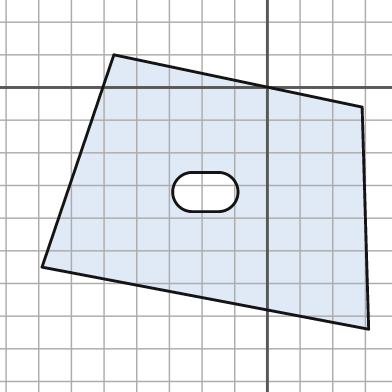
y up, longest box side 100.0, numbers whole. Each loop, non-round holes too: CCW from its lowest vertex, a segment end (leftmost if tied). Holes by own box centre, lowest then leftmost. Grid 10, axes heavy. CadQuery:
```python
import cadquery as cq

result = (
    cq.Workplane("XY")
    .moveTo(31.0, -74.0)
    .lineTo(29.0, -6.0)
    .lineTo(-47.0, 10.0)
    .lineTo(-69.0, -55.0)
    .close()
    .moveTo(-23.0, -38.0)
    .lineTo(-15.0, -38.0)
    .threePointArc((-9.0, -32.0), (-15.0, -26.0))
    .lineTo(-23.0, -26.0)
    .threePointArc((-29.0, -32.0), (-23.0, -38.0))
    .close()
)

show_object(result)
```